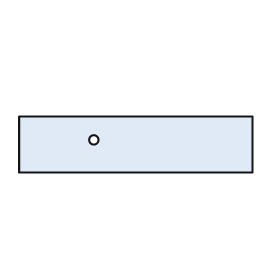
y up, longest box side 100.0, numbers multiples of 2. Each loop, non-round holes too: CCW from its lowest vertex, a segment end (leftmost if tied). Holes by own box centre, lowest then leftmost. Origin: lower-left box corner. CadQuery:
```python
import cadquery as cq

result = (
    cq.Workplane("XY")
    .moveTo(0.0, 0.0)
    .lineTo(100.0, 0.0)
    .lineTo(100.0, 24.0)
    .lineTo(0.0, 24.0)
    .close()
    .moveTo(32.0, 14.0)
    .circle(2.0)
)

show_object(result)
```